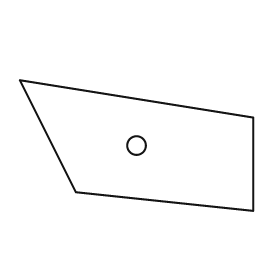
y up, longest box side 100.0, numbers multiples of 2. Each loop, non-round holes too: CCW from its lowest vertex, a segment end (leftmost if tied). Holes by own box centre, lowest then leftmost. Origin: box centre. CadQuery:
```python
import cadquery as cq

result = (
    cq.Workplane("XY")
    .moveTo(50.0, -28.0)
    .lineTo(50.0, 12.0)
    .lineTo(-50.0, 28.0)
    .lineTo(-26.0, -20.0)
    .close()
    .moveTo(0.0, 0.0)
    .circle(4.0)
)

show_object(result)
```